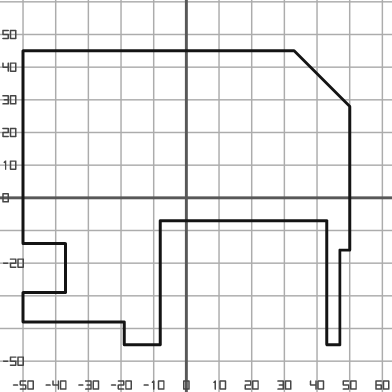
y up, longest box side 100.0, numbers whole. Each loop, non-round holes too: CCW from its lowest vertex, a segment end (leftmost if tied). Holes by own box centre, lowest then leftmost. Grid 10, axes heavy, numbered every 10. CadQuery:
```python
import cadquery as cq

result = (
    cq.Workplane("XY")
    .moveTo(-19.0, -45.0)
    .lineTo(-8.0, -45.0)
    .lineTo(-8.0, -7.0)
    .lineTo(43.0, -7.0)
    .lineTo(43.0, -45.0)
    .lineTo(47.0, -45.0)
    .lineTo(47.0, -16.0)
    .lineTo(50.0, -16.0)
    .lineTo(50.0, 28.0)
    .lineTo(33.0, 45.0)
    .lineTo(-50.0, 45.0)
    .lineTo(-50.0, -14.0)
    .lineTo(-37.0, -14.0)
    .lineTo(-37.0, -29.0)
    .lineTo(-50.0, -29.0)
    .lineTo(-50.0, -38.0)
    .lineTo(-19.0, -38.0)
    .close()
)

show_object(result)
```